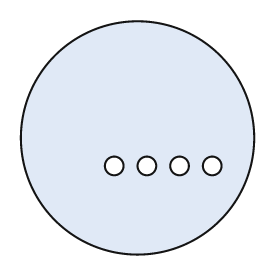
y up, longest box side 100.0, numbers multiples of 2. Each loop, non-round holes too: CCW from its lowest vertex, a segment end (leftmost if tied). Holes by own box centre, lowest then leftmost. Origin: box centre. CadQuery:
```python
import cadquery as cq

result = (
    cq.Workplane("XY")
    .moveTo(0.0, 0.0)
    .circle(50.0)
    .moveTo(-10.0, -12.0)
    .circle(4.0)
    .moveTo(4.0, -12.0)
    .circle(4.0)
    .moveTo(18.0, -12.0)
    .circle(4.0)
    .moveTo(32.0, -12.0)
    .circle(4.0)
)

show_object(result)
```